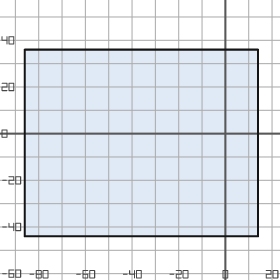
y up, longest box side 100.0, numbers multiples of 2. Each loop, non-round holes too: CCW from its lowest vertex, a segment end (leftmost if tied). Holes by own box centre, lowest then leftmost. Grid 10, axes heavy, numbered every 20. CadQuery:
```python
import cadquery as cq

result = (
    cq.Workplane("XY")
    .moveTo(-86.0, -44.0)
    .lineTo(14.0, -44.0)
    .lineTo(14.0, 36.0)
    .lineTo(-86.0, 36.0)
    .close()
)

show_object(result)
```